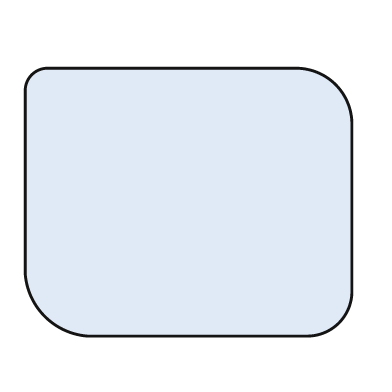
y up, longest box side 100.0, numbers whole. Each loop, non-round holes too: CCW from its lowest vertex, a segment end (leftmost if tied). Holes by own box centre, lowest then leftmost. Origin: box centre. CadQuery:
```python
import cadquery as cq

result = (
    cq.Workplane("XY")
    .moveTo(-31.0, -41.0)
    .lineTo(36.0, -41.0)
    .threePointArc((46.0, -37.0), (50.0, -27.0))
    .lineTo(50.0, 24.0)
    .threePointArc((45.0, 36.0), (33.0, 41.0))
    .lineTo(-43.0, 41.0)
    .threePointArc((-48.0, 39.0), (-50.0, 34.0))
    .lineTo(-50.0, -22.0)
    .threePointArc((-44.0, -35.0), (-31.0, -41.0))
    .close()
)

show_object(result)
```